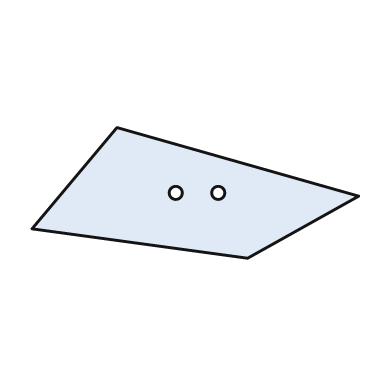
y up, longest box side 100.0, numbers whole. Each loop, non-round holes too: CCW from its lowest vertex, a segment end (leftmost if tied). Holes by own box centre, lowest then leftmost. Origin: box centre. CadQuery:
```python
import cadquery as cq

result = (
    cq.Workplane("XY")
    .moveTo(16.0, -20.0)
    .lineTo(50.0, -1.0)
    .lineTo(-24.0, 20.0)
    .lineTo(-50.0, -11.0)
    .close()
    .moveTo(-6.0, 0.0)
    .circle(2.0)
    .moveTo(7.0, 0.0)
    .circle(2.0)
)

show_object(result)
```